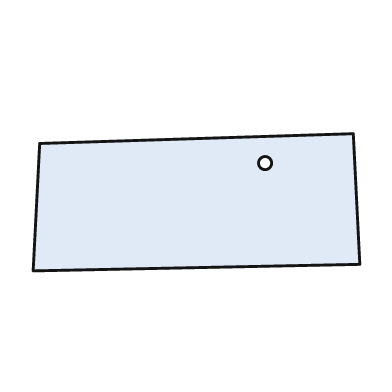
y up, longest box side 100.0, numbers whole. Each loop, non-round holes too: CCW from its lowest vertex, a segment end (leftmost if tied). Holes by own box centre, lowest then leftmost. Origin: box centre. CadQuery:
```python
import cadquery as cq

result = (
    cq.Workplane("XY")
    .moveTo(-50.0, -21.0)
    .lineTo(50.0, -19.0)
    .lineTo(48.0, 21.0)
    .lineTo(-48.0, 18.0)
    .close()
    .moveTo(21.0, 12.0)
    .circle(2.0)
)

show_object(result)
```